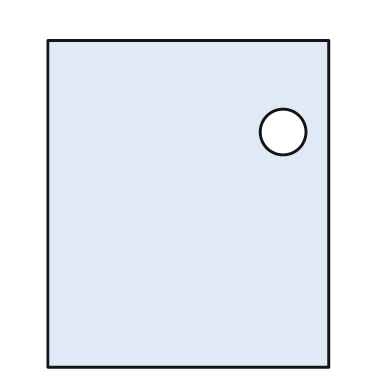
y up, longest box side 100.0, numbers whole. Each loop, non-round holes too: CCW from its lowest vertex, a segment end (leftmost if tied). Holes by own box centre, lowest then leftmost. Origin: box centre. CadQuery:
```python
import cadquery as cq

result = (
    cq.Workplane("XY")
    .moveTo(-43.0, -50.0)
    .lineTo(43.0, -50.0)
    .lineTo(43.0, 50.0)
    .lineTo(-43.0, 50.0)
    .close()
    .moveTo(29.0, 22.0)
    .circle(7.0)
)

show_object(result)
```